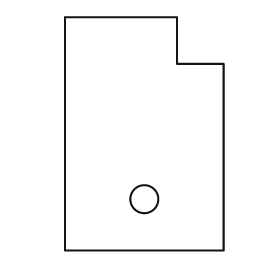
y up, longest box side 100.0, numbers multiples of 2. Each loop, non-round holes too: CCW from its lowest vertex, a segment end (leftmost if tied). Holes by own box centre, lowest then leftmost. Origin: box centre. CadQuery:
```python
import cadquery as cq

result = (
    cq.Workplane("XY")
    .moveTo(-34.0, -50.0)
    .lineTo(34.0, -50.0)
    .lineTo(34.0, 30.0)
    .lineTo(14.0, 30.0)
    .lineTo(14.0, 50.0)
    .lineTo(-34.0, 50.0)
    .close()
    .moveTo(0.0, -28.0)
    .circle(6.0)
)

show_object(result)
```